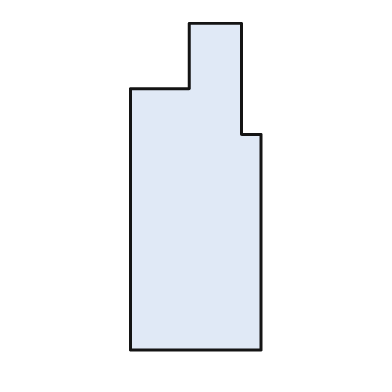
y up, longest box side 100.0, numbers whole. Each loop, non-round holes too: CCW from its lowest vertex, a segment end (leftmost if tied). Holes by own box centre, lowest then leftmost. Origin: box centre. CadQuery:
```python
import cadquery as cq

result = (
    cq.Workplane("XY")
    .moveTo(-20.0, -50.0)
    .lineTo(20.0, -50.0)
    .lineTo(20.0, 16.0)
    .lineTo(14.0, 16.0)
    .lineTo(14.0, 50.0)
    .lineTo(-2.0, 50.0)
    .lineTo(-2.0, 30.0)
    .lineTo(-20.0, 30.0)
    .close()
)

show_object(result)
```